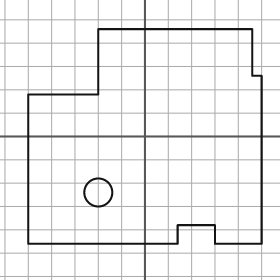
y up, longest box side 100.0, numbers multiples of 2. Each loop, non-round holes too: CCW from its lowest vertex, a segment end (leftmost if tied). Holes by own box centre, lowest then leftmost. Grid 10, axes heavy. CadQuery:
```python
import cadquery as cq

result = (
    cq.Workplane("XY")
    .moveTo(-50.0, -46.0)
    .lineTo(14.0, -46.0)
    .lineTo(14.0, -38.0)
    .lineTo(30.0, -38.0)
    .lineTo(30.0, -46.0)
    .lineTo(50.0, -46.0)
    .lineTo(50.0, 26.0)
    .lineTo(46.0, 26.0)
    .lineTo(46.0, 46.0)
    .lineTo(-20.0, 46.0)
    .lineTo(-20.0, 18.0)
    .lineTo(-50.0, 18.0)
    .close()
    .moveTo(-20.0, -24.0)
    .circle(6.0)
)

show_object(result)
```